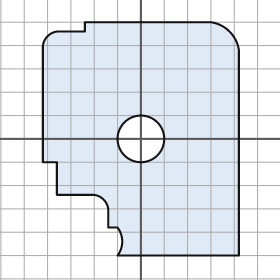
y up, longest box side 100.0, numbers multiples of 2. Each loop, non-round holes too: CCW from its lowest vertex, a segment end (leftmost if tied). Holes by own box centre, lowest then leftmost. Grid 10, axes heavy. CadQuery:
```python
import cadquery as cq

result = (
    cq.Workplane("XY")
    .moveTo(-10.0, -50.0)
    .lineTo(42.0, -50.0)
    .lineTo(42.0, 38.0)
    .threePointArc((38.0, 46.0), (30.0, 50.0))
    .lineTo(-24.0, 50.0)
    .lineTo(-24.0, 46.0)
    .lineTo(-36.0, 46.0)
    .threePointArc((-40.0, 44.0), (-42.0, 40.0))
    .lineTo(-42.0, -10.0)
    .lineTo(-36.0, -10.0)
    .lineTo(-36.0, -24.0)
    .lineTo(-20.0, -24.0)
    .threePointArc((-16.0, -26.0), (-14.0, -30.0))
    .lineTo(-14.0, -38.0)
    .lineTo(-10.0, -38.0)
    .threePointArc((-8.0, -44.0), (-10.0, -50.0))
    .close()
    .moveTo(0.0, 0.0)
    .circle(10.0)
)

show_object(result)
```